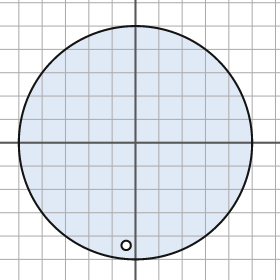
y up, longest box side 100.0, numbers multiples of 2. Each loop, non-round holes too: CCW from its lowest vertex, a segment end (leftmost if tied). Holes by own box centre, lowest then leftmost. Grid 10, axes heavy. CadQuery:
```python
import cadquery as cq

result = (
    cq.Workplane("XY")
    .moveTo(0.0, 0.0)
    .circle(50.0)
    .moveTo(-4.0, -44.0)
    .circle(2.0)
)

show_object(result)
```